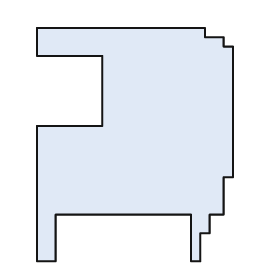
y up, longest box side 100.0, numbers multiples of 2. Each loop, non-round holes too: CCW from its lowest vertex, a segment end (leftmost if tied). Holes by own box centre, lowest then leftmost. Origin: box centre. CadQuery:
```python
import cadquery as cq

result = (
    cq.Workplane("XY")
    .moveTo(-42.0, -50.0)
    .lineTo(-34.0, -50.0)
    .lineTo(-34.0, -30.0)
    .lineTo(24.0, -30.0)
    .lineTo(24.0, -50.0)
    .lineTo(28.0, -50.0)
    .lineTo(28.0, -38.0)
    .lineTo(32.0, -38.0)
    .lineTo(32.0, -30.0)
    .lineTo(38.0, -30.0)
    .lineTo(38.0, -14.0)
    .lineTo(42.0, -14.0)
    .lineTo(42.0, 42.0)
    .lineTo(38.0, 42.0)
    .lineTo(38.0, 46.0)
    .lineTo(30.0, 46.0)
    .lineTo(30.0, 50.0)
    .lineTo(-42.0, 50.0)
    .lineTo(-42.0, 38.0)
    .lineTo(-14.0, 38.0)
    .lineTo(-14.0, 8.0)
    .lineTo(-42.0, 8.0)
    .close()
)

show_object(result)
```